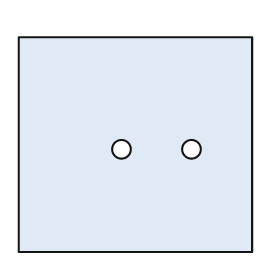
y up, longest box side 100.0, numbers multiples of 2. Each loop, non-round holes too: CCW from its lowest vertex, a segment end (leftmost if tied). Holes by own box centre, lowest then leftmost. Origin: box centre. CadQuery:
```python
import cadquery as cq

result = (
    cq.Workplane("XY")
    .moveTo(-50.0, -46.0)
    .lineTo(50.0, -46.0)
    .lineTo(50.0, 46.0)
    .lineTo(-50.0, 46.0)
    .close()
    .moveTo(-6.0, -2.0)
    .circle(4.0)
    .moveTo(24.0, -2.0)
    .circle(4.0)
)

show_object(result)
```